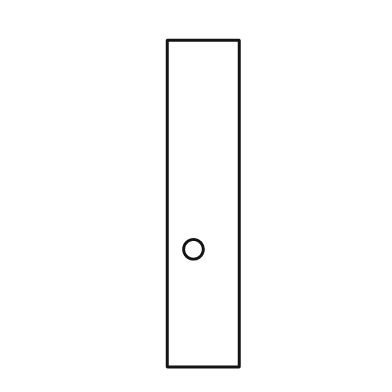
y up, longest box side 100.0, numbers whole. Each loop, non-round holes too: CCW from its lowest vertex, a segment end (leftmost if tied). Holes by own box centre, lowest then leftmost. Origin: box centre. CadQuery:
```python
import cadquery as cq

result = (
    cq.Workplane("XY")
    .moveTo(-11.0, -50.0)
    .lineTo(11.0, -50.0)
    .lineTo(11.0, 50.0)
    .lineTo(-11.0, 50.0)
    .close()
    .moveTo(-3.0, -14.0)
    .circle(3.0)
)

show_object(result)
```